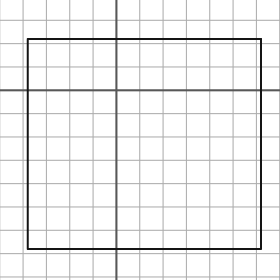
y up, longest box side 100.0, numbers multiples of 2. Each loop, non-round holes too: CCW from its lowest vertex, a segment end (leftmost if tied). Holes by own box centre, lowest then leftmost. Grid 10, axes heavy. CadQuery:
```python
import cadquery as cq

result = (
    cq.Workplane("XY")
    .moveTo(-38.0, -68.0)
    .lineTo(62.0, -68.0)
    .lineTo(62.0, 22.0)
    .lineTo(-38.0, 22.0)
    .close()
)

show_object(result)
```